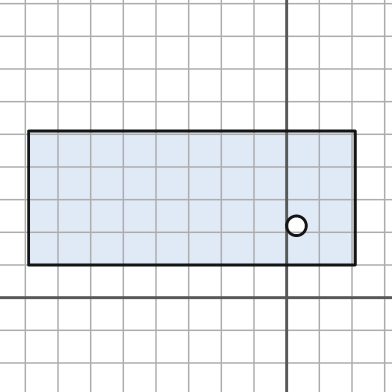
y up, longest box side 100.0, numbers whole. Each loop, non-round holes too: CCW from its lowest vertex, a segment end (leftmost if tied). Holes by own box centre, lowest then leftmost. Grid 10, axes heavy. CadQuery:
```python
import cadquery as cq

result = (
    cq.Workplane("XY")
    .moveTo(-79.0, 10.0)
    .lineTo(21.0, 10.0)
    .lineTo(21.0, 51.0)
    .lineTo(-79.0, 51.0)
    .close()
    .moveTo(3.0, 22.0)
    .circle(3.0)
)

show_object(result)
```